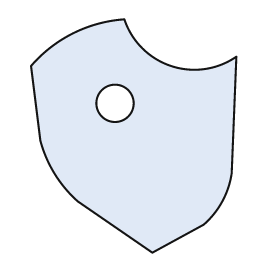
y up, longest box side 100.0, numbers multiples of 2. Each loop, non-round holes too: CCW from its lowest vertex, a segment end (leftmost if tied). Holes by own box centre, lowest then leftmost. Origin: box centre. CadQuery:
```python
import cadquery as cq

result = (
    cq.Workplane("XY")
    .moveTo(8.0, -50.0)
    .lineTo(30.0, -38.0)
    .threePointArc((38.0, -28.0), (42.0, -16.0))
    .lineTo(44.0, 34.0)
    .threePointArc((16.0, 30.0), (-4.0, 50.0))
    .threePointArc((-26.0, 44.0), (-44.0, 30.0))
    .lineTo(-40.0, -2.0)
    .threePointArc((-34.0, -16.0), (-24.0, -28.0))
    .close()
    .moveTo(-8.0, 14.0)
    .circle(8.0)
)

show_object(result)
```